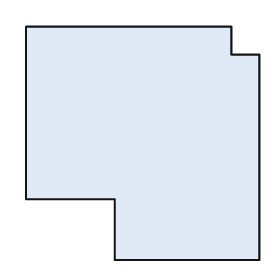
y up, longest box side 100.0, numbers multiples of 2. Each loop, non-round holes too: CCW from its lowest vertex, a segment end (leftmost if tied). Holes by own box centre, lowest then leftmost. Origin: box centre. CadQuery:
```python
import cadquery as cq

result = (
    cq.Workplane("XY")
    .moveTo(-12.0, -50.0)
    .lineTo(50.0, -50.0)
    .lineTo(50.0, 38.0)
    .lineTo(38.0, 38.0)
    .lineTo(38.0, 50.0)
    .lineTo(-50.0, 50.0)
    .lineTo(-50.0, -24.0)
    .lineTo(-12.0, -24.0)
    .close()
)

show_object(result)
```